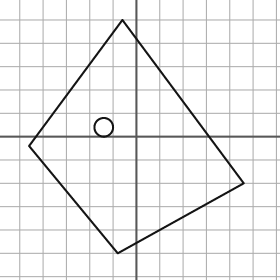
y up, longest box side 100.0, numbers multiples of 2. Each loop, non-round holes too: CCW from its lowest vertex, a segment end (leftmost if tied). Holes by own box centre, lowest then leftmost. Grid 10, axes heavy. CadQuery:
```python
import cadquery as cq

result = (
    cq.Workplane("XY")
    .moveTo(-8.0, -50.0)
    .lineTo(46.0, -20.0)
    .lineTo(-6.0, 50.0)
    .lineTo(-46.0, -4.0)
    .close()
    .moveTo(-14.0, 4.0)
    .circle(4.0)
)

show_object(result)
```